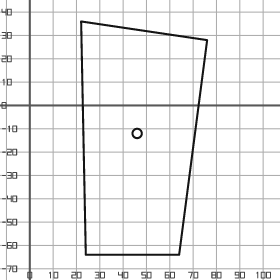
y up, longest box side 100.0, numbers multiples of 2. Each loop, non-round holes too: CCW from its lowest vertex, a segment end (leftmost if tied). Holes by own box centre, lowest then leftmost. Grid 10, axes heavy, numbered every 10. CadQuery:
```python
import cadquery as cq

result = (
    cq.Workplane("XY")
    .moveTo(24.0, -64.0)
    .lineTo(64.0, -64.0)
    .lineTo(76.0, 28.0)
    .lineTo(22.0, 36.0)
    .close()
    .moveTo(46.0, -12.0)
    .circle(2.0)
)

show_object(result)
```